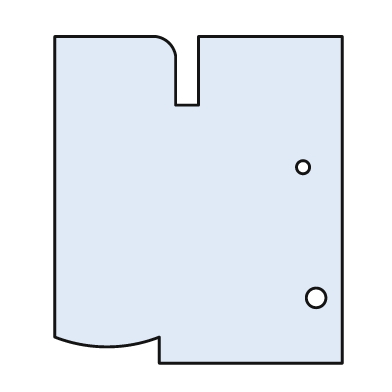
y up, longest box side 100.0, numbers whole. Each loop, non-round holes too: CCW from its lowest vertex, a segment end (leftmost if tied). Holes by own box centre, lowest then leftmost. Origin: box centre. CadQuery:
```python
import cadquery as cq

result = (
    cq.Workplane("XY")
    .moveTo(-12.0, -50.0)
    .lineTo(44.0, -50.0)
    .lineTo(44.0, 50.0)
    .lineTo(0.0, 50.0)
    .lineTo(0.0, 29.0)
    .lineTo(-7.0, 29.0)
    .lineTo(-7.0, 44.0)
    .threePointArc((-9.0, 48.0), (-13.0, 50.0))
    .lineTo(-44.0, 50.0)
    .lineTo(-44.0, -42.0)
    .threePointArc((-28.0, -45.0), (-12.0, -42.0))
    .close()
    .moveTo(36.0, -30.0)
    .circle(3.0)
    .moveTo(32.0, 10.0)
    .circle(2.0)
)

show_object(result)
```